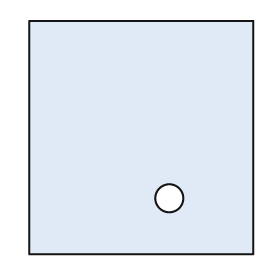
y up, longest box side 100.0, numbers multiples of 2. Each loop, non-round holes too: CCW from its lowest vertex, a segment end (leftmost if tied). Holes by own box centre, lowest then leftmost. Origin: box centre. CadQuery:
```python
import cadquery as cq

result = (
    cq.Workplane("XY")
    .moveTo(-48.0, -50.0)
    .lineTo(48.0, -50.0)
    .lineTo(48.0, 50.0)
    .lineTo(-48.0, 50.0)
    .close()
    .moveTo(12.0, -26.0)
    .circle(6.0)
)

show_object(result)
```